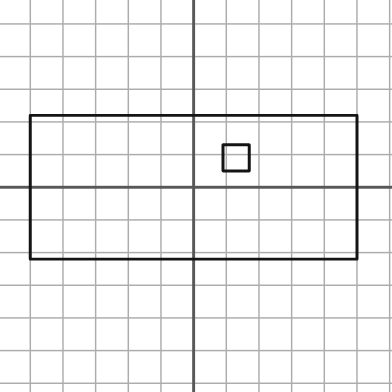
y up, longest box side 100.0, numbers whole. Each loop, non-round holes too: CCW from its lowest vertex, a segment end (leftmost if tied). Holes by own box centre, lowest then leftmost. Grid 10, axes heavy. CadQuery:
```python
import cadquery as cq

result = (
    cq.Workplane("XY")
    .moveTo(-50.0, -22.0)
    .lineTo(50.0, -22.0)
    .lineTo(50.0, 22.0)
    .lineTo(-50.0, 22.0)
    .close()
    .moveTo(9.0, 5.0)
    .lineTo(17.0, 5.0)
    .lineTo(17.0, 13.0)
    .lineTo(9.0, 13.0)
    .close()
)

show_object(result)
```